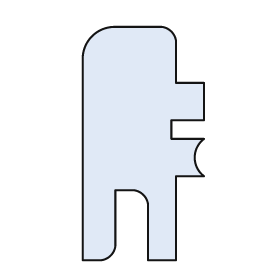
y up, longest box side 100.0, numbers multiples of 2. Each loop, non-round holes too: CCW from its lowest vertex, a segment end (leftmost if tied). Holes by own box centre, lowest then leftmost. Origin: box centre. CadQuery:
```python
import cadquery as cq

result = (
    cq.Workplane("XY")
    .moveTo(-26.0, -50.0)
    .lineTo(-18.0, -50.0)
    .threePointArc((-14.0, -48.0), (-12.0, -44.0))
    .lineTo(-12.0, -20.0)
    .lineTo(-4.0, -20.0)
    .threePointArc((0.0, -22.0), (2.0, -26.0))
    .lineTo(2.0, -50.0)
    .lineTo(14.0, -50.0)
    .lineTo(14.0, -14.0)
    .lineTo(26.0, -14.0)
    .threePointArc((22.0, -6.0), (26.0, 2.0))
    .lineTo(12.0, 2.0)
    .lineTo(12.0, 10.0)
    .lineTo(26.0, 10.0)
    .lineTo(26.0, 26.0)
    .lineTo(14.0, 26.0)
    .lineTo(14.0, 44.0)
    .threePointArc((12.0, 48.0), (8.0, 50.0))
    .lineTo(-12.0, 50.0)
    .threePointArc((-22.0, 46.0), (-26.0, 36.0))
    .close()
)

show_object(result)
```